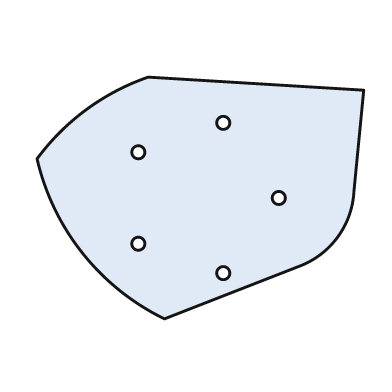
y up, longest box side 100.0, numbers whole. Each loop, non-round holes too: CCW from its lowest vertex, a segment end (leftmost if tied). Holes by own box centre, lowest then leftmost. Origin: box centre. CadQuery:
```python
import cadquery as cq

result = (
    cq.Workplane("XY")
    .moveTo(-11.0, -37.0)
    .lineTo(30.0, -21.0)
    .threePointArc((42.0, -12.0), (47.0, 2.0))
    .lineTo(50.0, 33.0)
    .lineTo(-16.0, 37.0)
    .threePointArc((-35.0, 27.0), (-50.0, 12.0))
    .threePointArc((-36.0, -17.0), (-11.0, -37.0))
    .close()
    .moveTo(7.0, -23.0)
    .circle(2.0)
    .moveTo(-19.0, -14.0)
    .circle(2.0)
    .moveTo(24.0, 0.0)
    .circle(2.0)
    .moveTo(-19.0, 14.0)
    .circle(2.0)
    .moveTo(7.0, 23.0)
    .circle(2.0)
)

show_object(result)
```